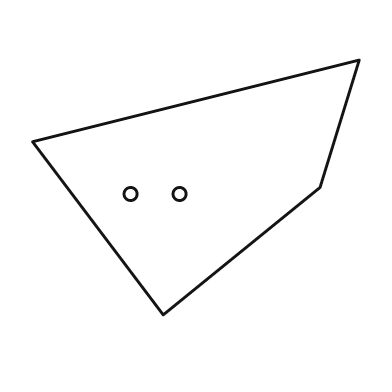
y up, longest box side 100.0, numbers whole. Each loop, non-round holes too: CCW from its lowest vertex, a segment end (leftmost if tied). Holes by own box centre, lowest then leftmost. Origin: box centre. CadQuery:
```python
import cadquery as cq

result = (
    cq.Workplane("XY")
    .moveTo(-10.0, -39.0)
    .lineTo(38.0, 0.0)
    .lineTo(50.0, 39.0)
    .lineTo(-50.0, 14.0)
    .close()
    .moveTo(-20.0, -2.0)
    .circle(2.0)
    .moveTo(-5.0, -2.0)
    .circle(2.0)
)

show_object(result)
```